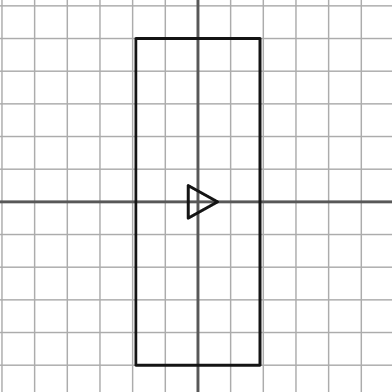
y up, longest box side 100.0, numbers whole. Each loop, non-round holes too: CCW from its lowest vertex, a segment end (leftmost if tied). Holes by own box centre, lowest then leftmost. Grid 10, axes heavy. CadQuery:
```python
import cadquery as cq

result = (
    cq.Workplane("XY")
    .moveTo(-19.0, -50.0)
    .lineTo(19.0, -50.0)
    .lineTo(19.0, 50.0)
    .lineTo(-19.0, 50.0)
    .close()
    .moveTo(-3.0, -5.0)
    .lineTo(6.0, 0.0)
    .lineTo(-3.0, 5.0)
    .close()
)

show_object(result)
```